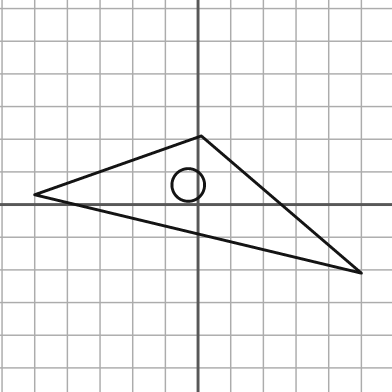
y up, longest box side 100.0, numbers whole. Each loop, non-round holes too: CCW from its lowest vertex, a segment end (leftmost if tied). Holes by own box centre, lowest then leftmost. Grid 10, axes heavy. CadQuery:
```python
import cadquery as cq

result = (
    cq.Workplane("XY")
    .moveTo(50.0, -21.0)
    .lineTo(1.0, 21.0)
    .lineTo(-50.0, 3.0)
    .close()
    .moveTo(-3.0, 6.0)
    .circle(5.0)
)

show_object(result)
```